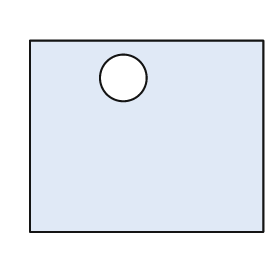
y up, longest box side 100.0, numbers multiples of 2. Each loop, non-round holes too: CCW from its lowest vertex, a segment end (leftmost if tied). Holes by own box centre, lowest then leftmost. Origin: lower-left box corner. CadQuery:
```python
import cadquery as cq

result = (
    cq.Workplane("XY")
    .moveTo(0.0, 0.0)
    .lineTo(100.0, 0.0)
    .lineTo(100.0, 82.0)
    .lineTo(0.0, 82.0)
    .close()
    .moveTo(40.0, 66.0)
    .circle(10.0)
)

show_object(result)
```